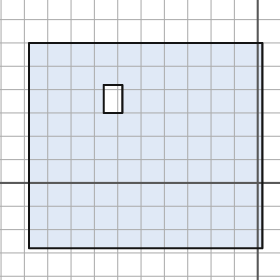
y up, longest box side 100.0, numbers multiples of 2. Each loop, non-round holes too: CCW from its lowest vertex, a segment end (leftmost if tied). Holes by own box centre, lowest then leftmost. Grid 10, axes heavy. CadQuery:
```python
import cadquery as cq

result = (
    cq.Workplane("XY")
    .moveTo(-98.0, -28.0)
    .lineTo(2.0, -28.0)
    .lineTo(2.0, 60.0)
    .lineTo(-98.0, 60.0)
    .close()
    .moveTo(-66.0, 30.0)
    .lineTo(-58.0, 30.0)
    .lineTo(-58.0, 42.0)
    .lineTo(-66.0, 42.0)
    .close()
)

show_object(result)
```